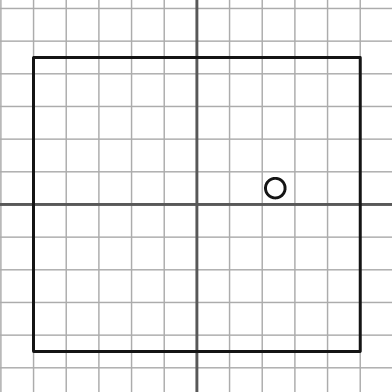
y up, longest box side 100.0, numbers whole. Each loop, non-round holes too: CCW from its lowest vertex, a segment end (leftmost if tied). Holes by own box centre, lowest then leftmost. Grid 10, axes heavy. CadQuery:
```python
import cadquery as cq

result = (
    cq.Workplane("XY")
    .moveTo(-50.0, -45.0)
    .lineTo(50.0, -45.0)
    .lineTo(50.0, 45.0)
    .lineTo(-50.0, 45.0)
    .close()
    .moveTo(24.0, 5.0)
    .circle(3.0)
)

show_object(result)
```